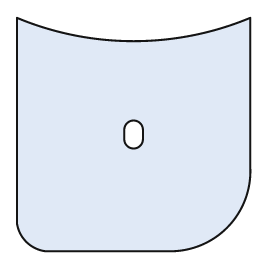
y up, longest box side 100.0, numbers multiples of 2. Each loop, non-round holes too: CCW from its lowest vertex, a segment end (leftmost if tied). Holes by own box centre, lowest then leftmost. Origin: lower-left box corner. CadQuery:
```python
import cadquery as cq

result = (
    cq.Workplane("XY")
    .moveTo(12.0, 0.0)
    .lineTo(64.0, 0.0)
    .threePointArc((90.0, 10.0), (100.0, 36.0))
    .lineTo(100.0, 100.0)
    .threePointArc((50.0, 90.0), (0.0, 100.0))
    .lineTo(0.0, 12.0)
    .threePointArc((4.0, 4.0), (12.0, 0.0))
    .close()
    .moveTo(46.0, 48.0)
    .threePointArc((50.0, 44.0), (54.0, 48.0))
    .lineTo(54.0, 52.0)
    .threePointArc((50.0, 56.0), (46.0, 52.0))
    .close()
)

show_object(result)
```